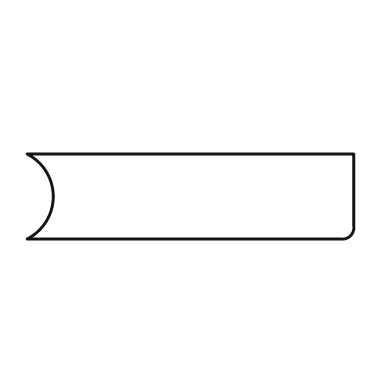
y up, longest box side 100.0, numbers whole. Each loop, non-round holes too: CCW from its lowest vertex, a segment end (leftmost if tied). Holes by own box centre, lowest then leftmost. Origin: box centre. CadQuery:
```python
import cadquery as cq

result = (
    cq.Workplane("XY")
    .moveTo(-50.0, -13.0)
    .lineTo(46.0, -13.0)
    .threePointArc((49.0, -12.0), (50.0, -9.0))
    .lineTo(50.0, 13.0)
    .lineTo(-50.0, 13.0)
    .threePointArc((-42.0, 0.0), (-50.0, -13.0))
    .close()
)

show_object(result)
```